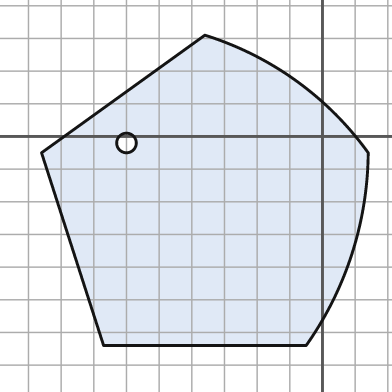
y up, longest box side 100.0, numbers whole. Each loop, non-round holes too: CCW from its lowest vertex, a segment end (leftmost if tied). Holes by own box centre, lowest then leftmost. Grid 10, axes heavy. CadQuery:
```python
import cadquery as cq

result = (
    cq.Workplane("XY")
    .moveTo(-67.0, -64.0)
    .lineTo(-5.0, -64.0)
    .threePointArc((9.0, -36.0), (14.0, -5.0))
    .threePointArc((-8.0, 17.0), (-36.0, 31.0))
    .lineTo(-86.0, -5.0)
    .close()
    .moveTo(-60.0, -2.0)
    .circle(3.0)
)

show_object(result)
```